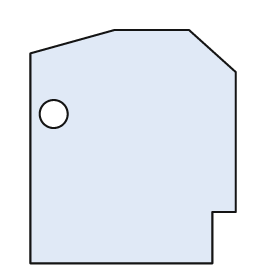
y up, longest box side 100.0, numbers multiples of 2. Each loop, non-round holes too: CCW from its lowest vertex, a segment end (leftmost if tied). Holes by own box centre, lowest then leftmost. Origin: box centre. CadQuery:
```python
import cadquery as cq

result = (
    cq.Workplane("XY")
    .moveTo(-44.0, -50.0)
    .lineTo(34.0, -50.0)
    .lineTo(34.0, -28.0)
    .lineTo(44.0, -28.0)
    .lineTo(44.0, 32.0)
    .lineTo(24.0, 50.0)
    .lineTo(-8.0, 50.0)
    .lineTo(-44.0, 40.0)
    .close()
    .moveTo(-34.0, 14.0)
    .circle(6.0)
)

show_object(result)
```